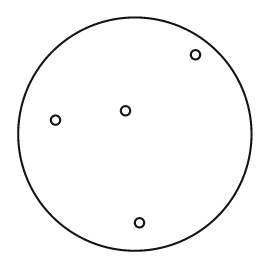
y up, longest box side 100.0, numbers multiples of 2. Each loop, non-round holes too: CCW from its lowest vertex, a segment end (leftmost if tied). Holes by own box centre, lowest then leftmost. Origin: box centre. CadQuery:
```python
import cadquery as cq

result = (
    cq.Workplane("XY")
    .moveTo(0.0, 0.0)
    .circle(50.0)
    .moveTo(2.0, -38.0)
    .circle(2.0)
    .moveTo(-34.0, 6.0)
    .circle(2.0)
    .moveTo(-4.0, 10.0)
    .circle(2.0)
    .moveTo(26.0, 34.0)
    .circle(2.0)
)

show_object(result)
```